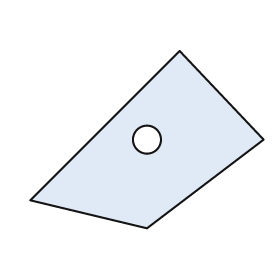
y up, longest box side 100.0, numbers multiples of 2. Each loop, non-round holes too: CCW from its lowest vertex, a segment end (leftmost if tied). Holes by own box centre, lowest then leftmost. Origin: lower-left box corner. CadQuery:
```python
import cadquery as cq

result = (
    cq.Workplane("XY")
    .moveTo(50.0, 0.0)
    .lineTo(100.0, 38.0)
    .lineTo(64.0, 76.0)
    .lineTo(0.0, 12.0)
    .close()
    .moveTo(50.0, 38.0)
    .circle(6.0)
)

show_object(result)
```